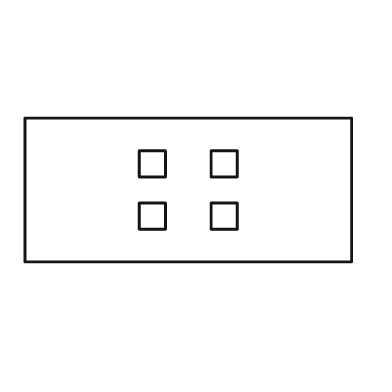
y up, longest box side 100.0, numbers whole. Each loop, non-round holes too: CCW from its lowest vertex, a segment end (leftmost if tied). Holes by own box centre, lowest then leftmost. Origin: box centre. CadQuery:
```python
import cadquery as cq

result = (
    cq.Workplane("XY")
    .moveTo(-50.0, -22.0)
    .lineTo(50.0, -22.0)
    .lineTo(50.0, 22.0)
    .lineTo(-50.0, 22.0)
    .close()
    .moveTo(-15.0, -12.0)
    .lineTo(-7.0, -12.0)
    .lineTo(-7.0, -4.0)
    .lineTo(-15.0, -4.0)
    .close()
    .moveTo(7.0, -12.0)
    .lineTo(15.0, -12.0)
    .lineTo(15.0, -4.0)
    .lineTo(7.0, -4.0)
    .close()
    .moveTo(-15.0, 4.0)
    .lineTo(-7.0, 4.0)
    .lineTo(-7.0, 12.0)
    .lineTo(-15.0, 12.0)
    .close()
    .moveTo(7.0, 4.0)
    .lineTo(15.0, 4.0)
    .lineTo(15.0, 12.0)
    .lineTo(7.0, 12.0)
    .close()
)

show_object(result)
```